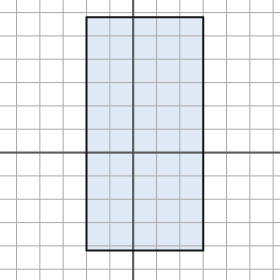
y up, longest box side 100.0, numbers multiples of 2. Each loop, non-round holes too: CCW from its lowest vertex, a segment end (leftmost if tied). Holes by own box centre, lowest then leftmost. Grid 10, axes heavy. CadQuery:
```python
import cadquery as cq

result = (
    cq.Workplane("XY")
    .moveTo(-20.0, -42.0)
    .lineTo(30.0, -42.0)
    .lineTo(30.0, 58.0)
    .lineTo(-20.0, 58.0)
    .close()
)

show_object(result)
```